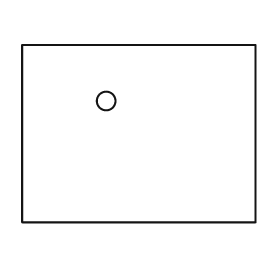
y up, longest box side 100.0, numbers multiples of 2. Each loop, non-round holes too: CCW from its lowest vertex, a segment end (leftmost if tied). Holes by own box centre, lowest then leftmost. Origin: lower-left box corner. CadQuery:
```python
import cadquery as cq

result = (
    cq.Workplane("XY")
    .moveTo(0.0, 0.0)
    .lineTo(100.0, 0.0)
    .lineTo(100.0, 76.0)
    .lineTo(0.0, 76.0)
    .close()
    .moveTo(36.0, 52.0)
    .circle(4.0)
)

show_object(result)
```